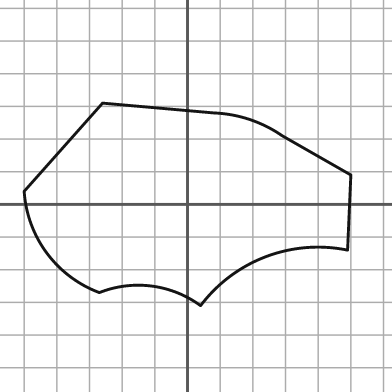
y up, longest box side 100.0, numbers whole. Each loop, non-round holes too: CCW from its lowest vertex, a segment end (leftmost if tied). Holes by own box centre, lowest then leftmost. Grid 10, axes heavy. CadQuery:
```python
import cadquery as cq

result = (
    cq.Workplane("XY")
    .moveTo(4.0, -31.0)
    .threePointArc((24.0, -16.0), (49.0, -14.0))
    .lineTo(50.0, 9.0)
    .lineTo(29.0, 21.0)
    .threePointArc((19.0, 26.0), (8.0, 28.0))
    .lineTo(-26.0, 31.0)
    .lineTo(-50.0, 4.0)
    .threePointArc((-43.0, -15.0), (-27.0, -27.0))
    .threePointArc((-11.0, -25.0), (4.0, -31.0))
    .close()
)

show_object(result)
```